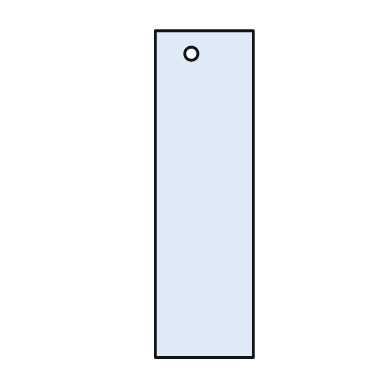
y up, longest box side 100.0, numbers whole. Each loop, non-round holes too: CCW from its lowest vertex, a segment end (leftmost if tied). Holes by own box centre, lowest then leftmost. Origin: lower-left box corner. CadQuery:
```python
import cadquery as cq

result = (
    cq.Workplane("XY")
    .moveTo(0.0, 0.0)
    .lineTo(30.0, 0.0)
    .lineTo(30.0, 100.0)
    .lineTo(0.0, 100.0)
    .close()
    .moveTo(11.0, 93.0)
    .circle(2.0)
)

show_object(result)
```